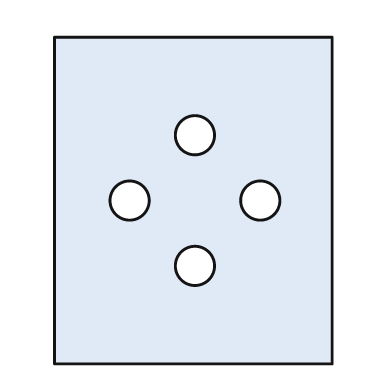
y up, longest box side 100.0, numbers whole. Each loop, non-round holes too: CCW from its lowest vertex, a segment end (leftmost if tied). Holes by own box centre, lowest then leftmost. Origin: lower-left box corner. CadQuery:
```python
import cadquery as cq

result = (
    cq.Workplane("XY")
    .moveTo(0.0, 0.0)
    .lineTo(85.0, 0.0)
    .lineTo(85.0, 100.0)
    .lineTo(0.0, 100.0)
    .close()
    .moveTo(43.0, 30.0)
    .circle(6.0)
    .moveTo(23.0, 50.0)
    .circle(6.0)
    .moveTo(63.0, 50.0)
    .circle(6.0)
    .moveTo(43.0, 70.0)
    .circle(6.0)
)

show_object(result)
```